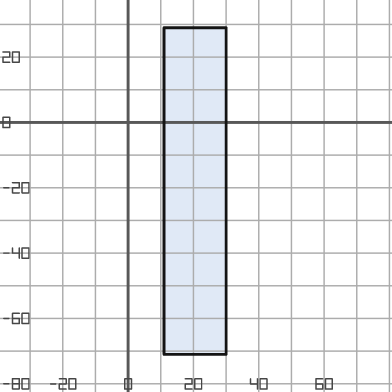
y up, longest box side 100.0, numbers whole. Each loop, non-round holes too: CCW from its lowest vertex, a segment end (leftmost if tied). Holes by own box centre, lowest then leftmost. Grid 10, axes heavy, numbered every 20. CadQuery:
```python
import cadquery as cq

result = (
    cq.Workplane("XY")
    .moveTo(11.0, -71.0)
    .lineTo(30.0, -71.0)
    .lineTo(30.0, 29.0)
    .lineTo(11.0, 29.0)
    .close()
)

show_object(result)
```